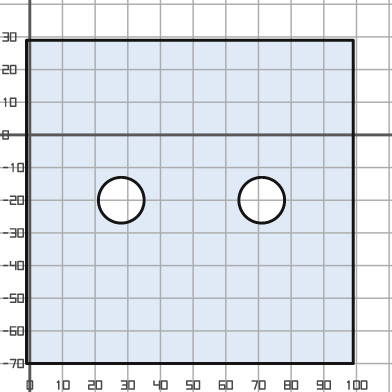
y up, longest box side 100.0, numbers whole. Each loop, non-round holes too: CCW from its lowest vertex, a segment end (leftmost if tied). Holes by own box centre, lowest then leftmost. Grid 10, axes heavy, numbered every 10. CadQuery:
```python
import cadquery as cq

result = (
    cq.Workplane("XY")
    .moveTo(-1.0, -70.0)
    .lineTo(99.0, -70.0)
    .lineTo(99.0, 29.0)
    .lineTo(-1.0, 29.0)
    .close()
    .moveTo(28.0, -20.0)
    .circle(7.0)
    .moveTo(71.0, -20.0)
    .circle(7.0)
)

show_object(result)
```